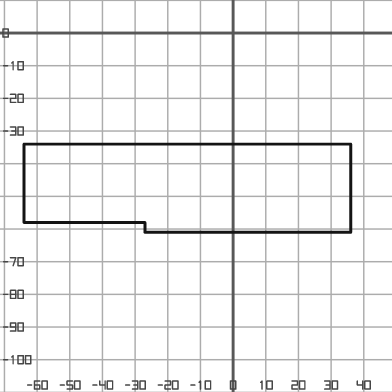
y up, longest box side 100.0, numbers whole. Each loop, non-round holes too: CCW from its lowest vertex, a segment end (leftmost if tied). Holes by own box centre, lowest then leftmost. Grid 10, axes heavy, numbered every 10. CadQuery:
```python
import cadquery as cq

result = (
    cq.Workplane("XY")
    .moveTo(-27.0, -61.0)
    .lineTo(36.0, -61.0)
    .lineTo(36.0, -34.0)
    .lineTo(-64.0, -34.0)
    .lineTo(-64.0, -58.0)
    .lineTo(-27.0, -58.0)
    .close()
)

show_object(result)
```